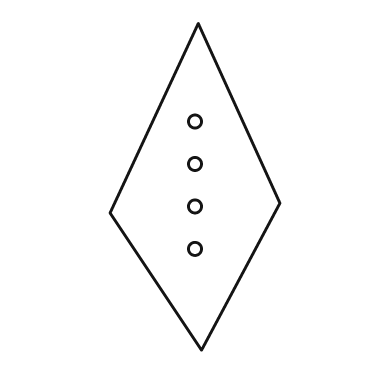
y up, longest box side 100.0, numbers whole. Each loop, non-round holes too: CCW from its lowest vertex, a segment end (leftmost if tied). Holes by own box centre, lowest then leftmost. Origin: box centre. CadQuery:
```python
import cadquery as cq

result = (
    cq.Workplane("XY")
    .moveTo(2.0, -50.0)
    .lineTo(26.0, -5.0)
    .lineTo(1.0, 50.0)
    .lineTo(-26.0, -8.0)
    .close()
    .moveTo(0.0, -19.0)
    .circle(2.0)
    .moveTo(0.0, -6.0)
    .circle(2.0)
    .moveTo(0.0, 7.0)
    .circle(2.0)
    .moveTo(0.0, 20.0)
    .circle(2.0)
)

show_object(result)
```